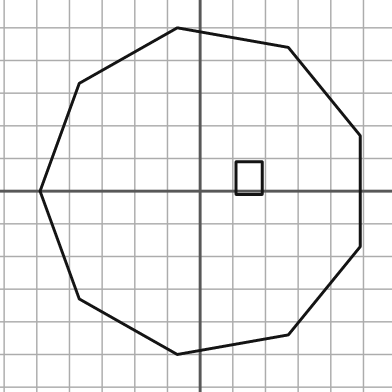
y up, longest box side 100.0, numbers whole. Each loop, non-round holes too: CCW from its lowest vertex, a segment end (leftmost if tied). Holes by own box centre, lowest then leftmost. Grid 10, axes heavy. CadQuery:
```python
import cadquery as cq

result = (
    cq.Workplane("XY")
    .moveTo(-7.0, -50.0)
    .lineTo(27.0, -44.0)
    .lineTo(49.0, -17.0)
    .lineTo(49.0, 17.0)
    .lineTo(27.0, 44.0)
    .lineTo(-7.0, 50.0)
    .lineTo(-37.0, 33.0)
    .lineTo(-49.0, 0.0)
    .lineTo(-37.0, -33.0)
    .close()
    .moveTo(11.0, -1.0)
    .lineTo(19.0, -1.0)
    .lineTo(19.0, 9.0)
    .lineTo(11.0, 9.0)
    .close()
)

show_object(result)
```